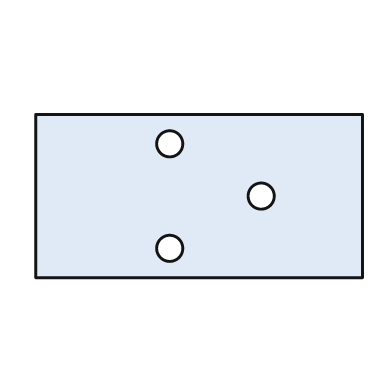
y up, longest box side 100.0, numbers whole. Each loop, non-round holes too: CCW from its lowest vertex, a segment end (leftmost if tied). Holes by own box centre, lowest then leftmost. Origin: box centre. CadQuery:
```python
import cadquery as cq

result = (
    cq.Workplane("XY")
    .moveTo(-50.0, -25.0)
    .lineTo(50.0, -25.0)
    .lineTo(50.0, 25.0)
    .lineTo(-50.0, 25.0)
    .close()
    .moveTo(-9.0, -16.0)
    .circle(4.0)
    .moveTo(19.0, 0.0)
    .circle(4.0)
    .moveTo(-9.0, 16.0)
    .circle(4.0)
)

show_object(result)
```